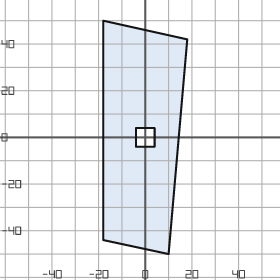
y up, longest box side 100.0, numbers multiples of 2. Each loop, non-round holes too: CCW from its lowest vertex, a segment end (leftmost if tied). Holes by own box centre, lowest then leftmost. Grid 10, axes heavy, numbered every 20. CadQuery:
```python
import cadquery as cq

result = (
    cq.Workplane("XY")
    .moveTo(10.0, -50.0)
    .lineTo(18.0, 42.0)
    .lineTo(-18.0, 50.0)
    .lineTo(-18.0, -44.0)
    .close()
    .moveTo(-4.0, -4.0)
    .lineTo(4.0, -4.0)
    .lineTo(4.0, 4.0)
    .lineTo(-4.0, 4.0)
    .close()
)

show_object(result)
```